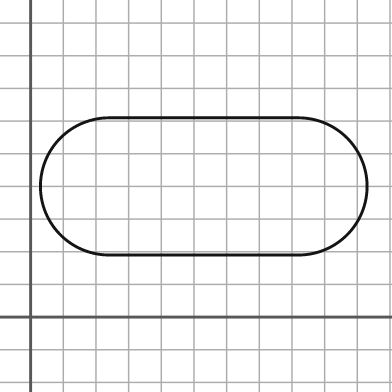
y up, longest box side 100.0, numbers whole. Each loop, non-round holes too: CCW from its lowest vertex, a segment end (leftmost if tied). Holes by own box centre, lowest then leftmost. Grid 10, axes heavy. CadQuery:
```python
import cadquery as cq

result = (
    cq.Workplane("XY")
    .moveTo(24.0, 19.0)
    .lineTo(82.0, 19.0)
    .threePointArc((103.0, 40.0), (82.0, 61.0))
    .lineTo(24.0, 61.0)
    .threePointArc((3.0, 40.0), (24.0, 19.0))
    .close()
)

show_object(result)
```